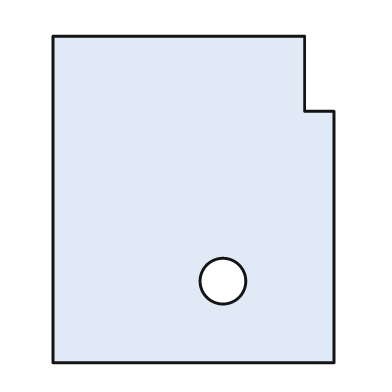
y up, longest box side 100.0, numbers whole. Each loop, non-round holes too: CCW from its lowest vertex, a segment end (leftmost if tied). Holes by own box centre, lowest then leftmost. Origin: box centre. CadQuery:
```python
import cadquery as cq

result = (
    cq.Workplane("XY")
    .moveTo(-43.0, -50.0)
    .lineTo(43.0, -50.0)
    .lineTo(43.0, 27.0)
    .lineTo(34.0, 27.0)
    .lineTo(34.0, 50.0)
    .lineTo(-43.0, 50.0)
    .close()
    .moveTo(9.0, -25.0)
    .circle(7.0)
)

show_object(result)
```